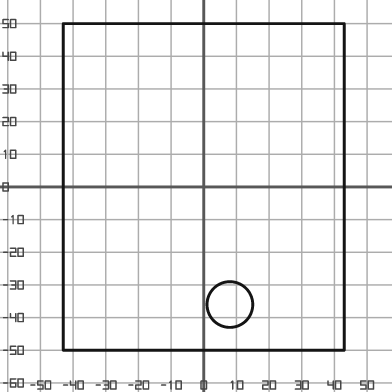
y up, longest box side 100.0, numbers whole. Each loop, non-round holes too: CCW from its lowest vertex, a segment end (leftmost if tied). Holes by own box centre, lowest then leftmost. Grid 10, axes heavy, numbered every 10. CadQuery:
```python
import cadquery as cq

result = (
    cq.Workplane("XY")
    .moveTo(-43.0, -50.0)
    .lineTo(43.0, -50.0)
    .lineTo(43.0, 50.0)
    .lineTo(-43.0, 50.0)
    .close()
    .moveTo(8.0, -36.0)
    .circle(7.0)
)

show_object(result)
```